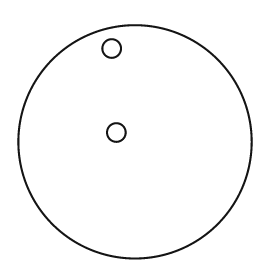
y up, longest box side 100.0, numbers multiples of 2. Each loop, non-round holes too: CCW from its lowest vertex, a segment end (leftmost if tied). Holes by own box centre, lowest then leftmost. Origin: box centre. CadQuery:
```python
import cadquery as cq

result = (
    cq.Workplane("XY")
    .moveTo(0.0, 0.0)
    .circle(50.0)
    .moveTo(-8.0, 4.0)
    .circle(4.0)
    .moveTo(-10.0, 40.0)
    .circle(4.0)
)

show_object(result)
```